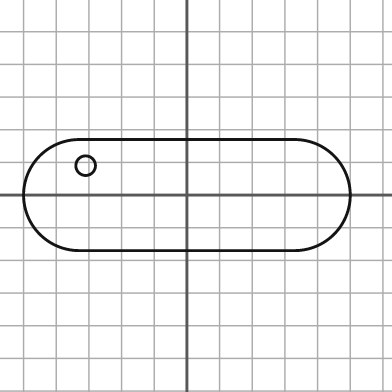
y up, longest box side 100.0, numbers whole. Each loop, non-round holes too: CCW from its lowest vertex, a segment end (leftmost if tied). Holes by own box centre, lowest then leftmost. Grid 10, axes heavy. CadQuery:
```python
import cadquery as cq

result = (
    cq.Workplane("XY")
    .moveTo(-33.0, -17.0)
    .lineTo(33.0, -17.0)
    .threePointArc((50.0, 0.0), (33.0, 17.0))
    .lineTo(-33.0, 17.0)
    .threePointArc((-50.0, 0.0), (-33.0, -17.0))
    .close()
    .moveTo(-31.0, 9.0)
    .circle(3.0)
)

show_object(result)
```